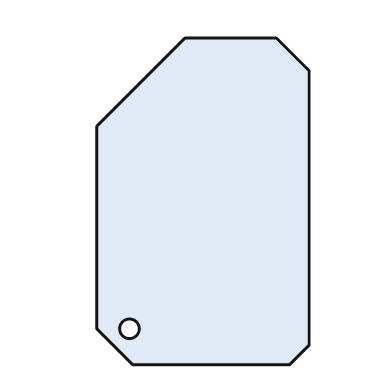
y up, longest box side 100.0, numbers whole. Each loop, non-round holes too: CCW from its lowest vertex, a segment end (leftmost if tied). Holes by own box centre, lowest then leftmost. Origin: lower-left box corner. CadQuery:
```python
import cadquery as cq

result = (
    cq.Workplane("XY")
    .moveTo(11.0, 0.0)
    .lineTo(59.0, 0.0)
    .lineTo(65.0, 6.0)
    .lineTo(65.0, 90.0)
    .lineTo(55.0, 100.0)
    .lineTo(27.0, 100.0)
    .lineTo(0.0, 73.0)
    .lineTo(0.0, 11.0)
    .close()
    .moveTo(10.0, 11.0)
    .circle(3.0)
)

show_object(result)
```